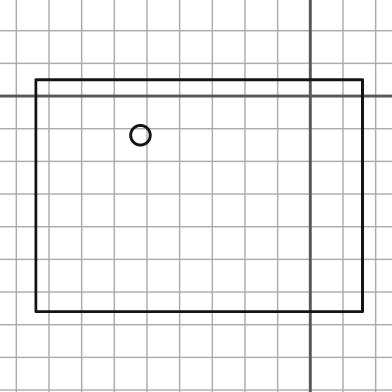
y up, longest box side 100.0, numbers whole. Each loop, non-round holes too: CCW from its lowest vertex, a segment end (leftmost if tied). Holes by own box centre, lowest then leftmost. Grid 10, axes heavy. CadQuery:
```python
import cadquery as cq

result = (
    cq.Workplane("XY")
    .moveTo(-84.0, -66.0)
    .lineTo(16.0, -66.0)
    .lineTo(16.0, 5.0)
    .lineTo(-84.0, 5.0)
    .close()
    .moveTo(-52.0, -12.0)
    .circle(3.0)
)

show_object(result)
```